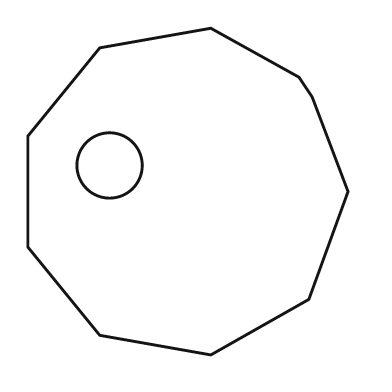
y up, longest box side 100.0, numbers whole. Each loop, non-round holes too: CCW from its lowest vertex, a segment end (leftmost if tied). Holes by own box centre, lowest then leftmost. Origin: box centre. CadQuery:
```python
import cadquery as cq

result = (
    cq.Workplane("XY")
    .moveTo(7.0, -50.0)
    .lineTo(37.0, -33.0)
    .lineTo(49.0, 0.0)
    .lineTo(38.0, 29.0)
    .lineTo(34.0, 35.0)
    .lineTo(7.0, 50.0)
    .lineTo(-27.0, 44.0)
    .lineTo(-49.0, 17.0)
    .lineTo(-49.0, -17.0)
    .lineTo(-27.0, -44.0)
    .close()
    .moveTo(-24.0, 8.0)
    .circle(10.0)
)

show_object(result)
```